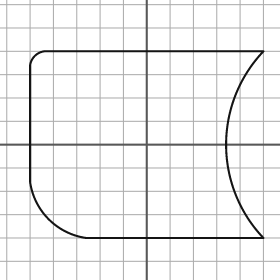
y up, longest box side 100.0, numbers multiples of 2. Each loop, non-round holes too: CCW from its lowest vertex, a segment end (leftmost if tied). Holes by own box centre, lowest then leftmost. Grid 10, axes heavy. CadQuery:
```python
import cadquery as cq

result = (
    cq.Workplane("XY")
    .moveTo(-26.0, -40.0)
    .lineTo(50.0, -40.0)
    .threePointArc((34.0, 0.0), (50.0, 40.0))
    .lineTo(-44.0, 40.0)
    .threePointArc((-48.0, 38.0), (-50.0, 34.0))
    .lineTo(-50.0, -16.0)
    .threePointArc((-42.0, -32.0), (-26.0, -40.0))
    .close()
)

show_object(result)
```